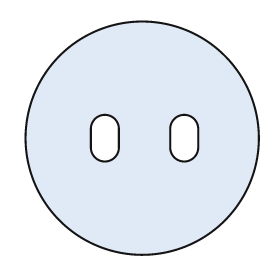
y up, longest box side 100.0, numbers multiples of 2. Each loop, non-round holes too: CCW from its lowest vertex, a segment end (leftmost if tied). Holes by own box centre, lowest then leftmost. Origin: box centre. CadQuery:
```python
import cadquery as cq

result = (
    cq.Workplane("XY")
    .moveTo(0.0, 0.0)
    .circle(50.0)
    .moveTo(-22.0, -4.0)
    .threePointArc((-16.0, -10.0), (-10.0, -4.0))
    .lineTo(-10.0, 4.0)
    .threePointArc((-16.0, 10.0), (-22.0, 4.0))
    .close()
    .moveTo(12.0, -4.0)
    .threePointArc((18.0, -10.0), (24.0, -4.0))
    .lineTo(24.0, 4.0)
    .threePointArc((18.0, 10.0), (12.0, 4.0))
    .close()
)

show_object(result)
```